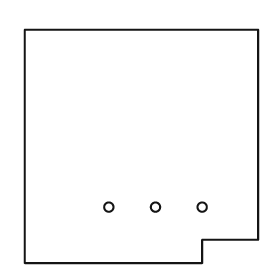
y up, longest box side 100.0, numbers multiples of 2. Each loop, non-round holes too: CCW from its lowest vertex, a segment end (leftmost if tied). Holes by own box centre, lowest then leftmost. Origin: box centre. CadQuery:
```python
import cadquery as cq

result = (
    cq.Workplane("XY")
    .moveTo(-50.0, -50.0)
    .lineTo(26.0, -50.0)
    .lineTo(26.0, -40.0)
    .lineTo(50.0, -40.0)
    .lineTo(50.0, 50.0)
    .lineTo(-50.0, 50.0)
    .close()
    .moveTo(-14.0, -26.0)
    .circle(2.0)
    .moveTo(6.0, -26.0)
    .circle(2.0)
    .moveTo(26.0, -26.0)
    .circle(2.0)
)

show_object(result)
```